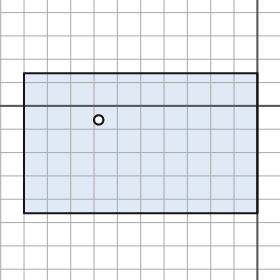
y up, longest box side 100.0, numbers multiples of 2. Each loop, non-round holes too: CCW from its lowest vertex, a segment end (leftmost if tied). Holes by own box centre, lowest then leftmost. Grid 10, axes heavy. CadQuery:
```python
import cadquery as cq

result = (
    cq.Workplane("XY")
    .moveTo(-100.0, -46.0)
    .lineTo(0.0, -46.0)
    .lineTo(0.0, 14.0)
    .lineTo(-100.0, 14.0)
    .close()
    .moveTo(-68.0, -6.0)
    .circle(2.0)
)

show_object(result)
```